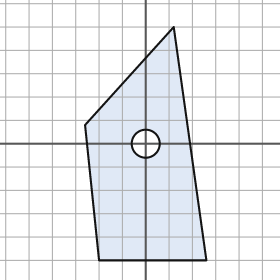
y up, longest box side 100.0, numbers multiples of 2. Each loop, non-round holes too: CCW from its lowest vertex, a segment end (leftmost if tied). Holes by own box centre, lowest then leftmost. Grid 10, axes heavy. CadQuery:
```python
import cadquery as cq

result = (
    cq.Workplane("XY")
    .moveTo(-20.0, -50.0)
    .lineTo(26.0, -50.0)
    .lineTo(12.0, 50.0)
    .lineTo(-26.0, 8.0)
    .close()
    .moveTo(0.0, 0.0)
    .circle(6.0)
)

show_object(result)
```